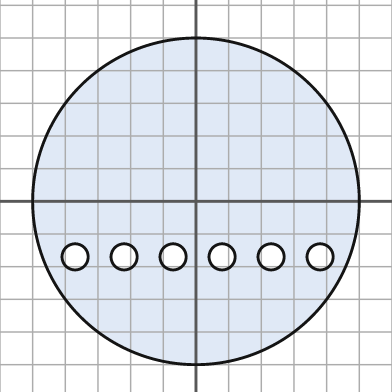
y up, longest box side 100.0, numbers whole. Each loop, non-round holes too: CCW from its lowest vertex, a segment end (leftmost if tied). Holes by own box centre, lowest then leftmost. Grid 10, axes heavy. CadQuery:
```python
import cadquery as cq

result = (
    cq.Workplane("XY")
    .moveTo(0.0, 0.0)
    .circle(50.0)
    .moveTo(-37.0, -17.0)
    .circle(4.0)
    .moveTo(-22.0, -17.0)
    .circle(4.0)
    .moveTo(-7.0, -17.0)
    .circle(4.0)
    .moveTo(8.0, -17.0)
    .circle(4.0)
    .moveTo(23.0, -17.0)
    .circle(4.0)
    .moveTo(38.0, -17.0)
    .circle(4.0)
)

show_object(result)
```